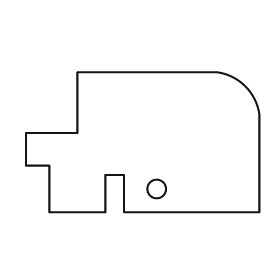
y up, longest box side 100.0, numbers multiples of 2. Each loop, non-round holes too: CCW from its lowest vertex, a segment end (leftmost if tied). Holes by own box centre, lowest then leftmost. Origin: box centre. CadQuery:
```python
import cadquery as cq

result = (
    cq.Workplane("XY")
    .moveTo(-40.0, -30.0)
    .lineTo(-16.0, -30.0)
    .lineTo(-16.0, -14.0)
    .lineTo(-8.0, -14.0)
    .lineTo(-8.0, -30.0)
    .lineTo(50.0, -30.0)
    .lineTo(50.0, 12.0)
    .threePointArc((44.0, 24.0), (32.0, 30.0))
    .lineTo(-28.0, 30.0)
    .lineTo(-28.0, 4.0)
    .lineTo(-50.0, 4.0)
    .lineTo(-50.0, -10.0)
    .lineTo(-40.0, -10.0)
    .close()
    .moveTo(6.0, -20.0)
    .circle(4.0)
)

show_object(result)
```